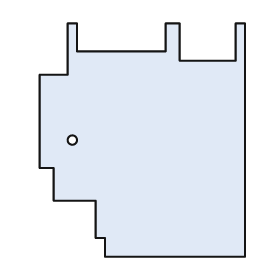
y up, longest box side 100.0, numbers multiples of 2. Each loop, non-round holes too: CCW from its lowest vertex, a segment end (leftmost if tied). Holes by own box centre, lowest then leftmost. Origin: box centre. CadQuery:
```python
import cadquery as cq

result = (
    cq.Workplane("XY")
    .moveTo(-16.0, -50.0)
    .lineTo(44.0, -50.0)
    .lineTo(44.0, 50.0)
    .lineTo(40.0, 50.0)
    .lineTo(40.0, 34.0)
    .lineTo(16.0, 34.0)
    .lineTo(16.0, 50.0)
    .lineTo(10.0, 50.0)
    .lineTo(10.0, 38.0)
    .lineTo(-28.0, 38.0)
    .lineTo(-28.0, 50.0)
    .lineTo(-32.0, 50.0)
    .lineTo(-32.0, 28.0)
    .lineTo(-44.0, 28.0)
    .lineTo(-44.0, -12.0)
    .lineTo(-38.0, -12.0)
    .lineTo(-38.0, -26.0)
    .lineTo(-20.0, -26.0)
    .lineTo(-20.0, -42.0)
    .lineTo(-16.0, -42.0)
    .close()
    .moveTo(-30.0, 0.0)
    .circle(2.0)
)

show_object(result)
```